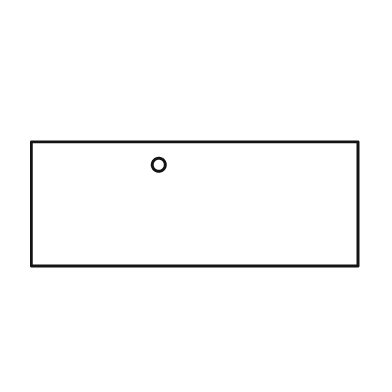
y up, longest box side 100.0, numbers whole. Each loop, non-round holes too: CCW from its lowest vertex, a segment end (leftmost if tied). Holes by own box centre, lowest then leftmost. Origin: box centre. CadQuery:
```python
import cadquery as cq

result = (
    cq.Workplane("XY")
    .moveTo(-50.0, -19.0)
    .lineTo(50.0, -19.0)
    .lineTo(50.0, 19.0)
    .lineTo(-50.0, 19.0)
    .close()
    .moveTo(-11.0, 12.0)
    .circle(2.0)
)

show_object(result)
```